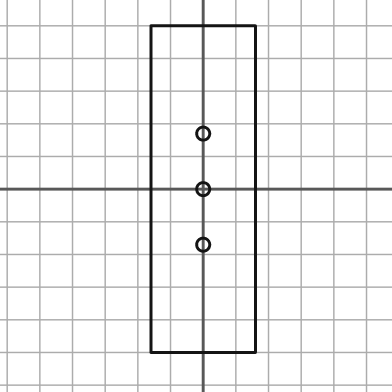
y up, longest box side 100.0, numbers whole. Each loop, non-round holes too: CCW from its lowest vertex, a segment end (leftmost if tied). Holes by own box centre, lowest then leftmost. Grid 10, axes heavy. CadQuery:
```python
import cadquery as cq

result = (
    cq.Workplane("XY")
    .moveTo(-16.0, -50.0)
    .lineTo(16.0, -50.0)
    .lineTo(16.0, 50.0)
    .lineTo(-16.0, 50.0)
    .close()
    .moveTo(0.0, -17.0)
    .circle(2.0)
    .moveTo(0.0, 0.0)
    .circle(2.0)
    .moveTo(0.0, 17.0)
    .circle(2.0)
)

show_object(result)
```